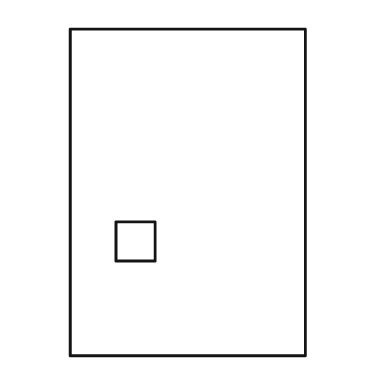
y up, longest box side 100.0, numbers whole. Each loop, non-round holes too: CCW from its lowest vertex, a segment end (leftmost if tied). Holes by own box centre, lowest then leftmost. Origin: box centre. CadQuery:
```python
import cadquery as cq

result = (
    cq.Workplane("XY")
    .moveTo(-36.0, -50.0)
    .lineTo(36.0, -50.0)
    .lineTo(36.0, 50.0)
    .lineTo(-36.0, 50.0)
    .close()
    .moveTo(-22.0, -21.0)
    .lineTo(-10.0, -21.0)
    .lineTo(-10.0, -9.0)
    .lineTo(-22.0, -9.0)
    .close()
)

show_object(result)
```